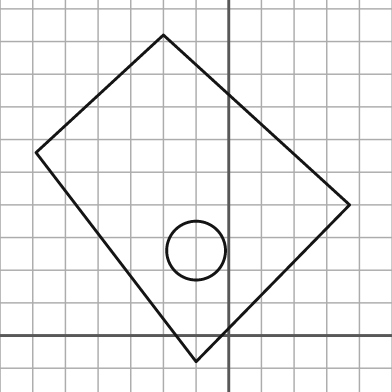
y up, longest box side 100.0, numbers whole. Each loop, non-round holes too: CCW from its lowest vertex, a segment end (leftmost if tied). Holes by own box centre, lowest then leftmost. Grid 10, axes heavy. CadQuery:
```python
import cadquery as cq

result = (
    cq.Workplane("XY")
    .moveTo(-10.0, -8.0)
    .lineTo(37.0, 40.0)
    .lineTo(-20.0, 92.0)
    .lineTo(-59.0, 56.0)
    .close()
    .moveTo(-10.0, 26.0)
    .circle(9.0)
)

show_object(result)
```